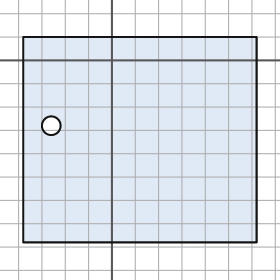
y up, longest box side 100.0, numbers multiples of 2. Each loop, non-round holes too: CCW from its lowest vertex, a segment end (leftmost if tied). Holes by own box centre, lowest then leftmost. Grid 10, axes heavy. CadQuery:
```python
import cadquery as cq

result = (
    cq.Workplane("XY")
    .moveTo(-38.0, -78.0)
    .lineTo(62.0, -78.0)
    .lineTo(62.0, 10.0)
    .lineTo(-38.0, 10.0)
    .close()
    .moveTo(-26.0, -28.0)
    .circle(4.0)
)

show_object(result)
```